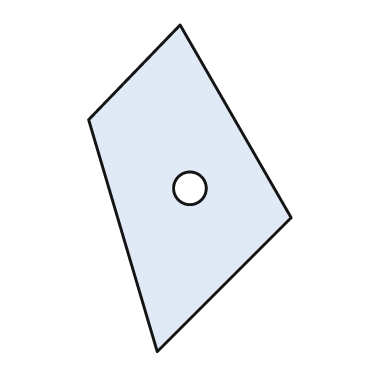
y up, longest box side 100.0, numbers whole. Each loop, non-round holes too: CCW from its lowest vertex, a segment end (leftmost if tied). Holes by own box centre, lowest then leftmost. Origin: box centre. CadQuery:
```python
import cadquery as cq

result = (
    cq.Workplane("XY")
    .moveTo(-10.0, -50.0)
    .lineTo(31.0, -9.0)
    .lineTo(-3.0, 50.0)
    .lineTo(-31.0, 21.0)
    .close()
    .moveTo(0.0, 0.0)
    .circle(5.0)
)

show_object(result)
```